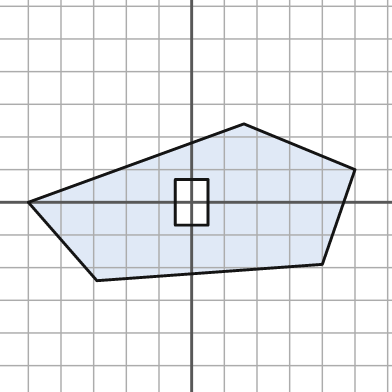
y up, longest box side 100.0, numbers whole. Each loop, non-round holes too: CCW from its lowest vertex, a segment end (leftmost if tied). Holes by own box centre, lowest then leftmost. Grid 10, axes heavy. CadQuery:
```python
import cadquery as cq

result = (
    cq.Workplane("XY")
    .moveTo(-29.0, -24.0)
    .lineTo(40.0, -19.0)
    .lineTo(50.0, 10.0)
    .lineTo(16.0, 24.0)
    .lineTo(-50.0, 0.0)
    .close()
    .moveTo(-5.0, -7.0)
    .lineTo(5.0, -7.0)
    .lineTo(5.0, 7.0)
    .lineTo(-5.0, 7.0)
    .close()
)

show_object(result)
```